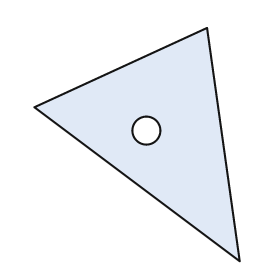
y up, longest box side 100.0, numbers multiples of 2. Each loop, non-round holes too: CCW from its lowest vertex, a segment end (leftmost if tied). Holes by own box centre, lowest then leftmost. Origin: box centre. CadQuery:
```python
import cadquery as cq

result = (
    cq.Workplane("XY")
    .moveTo(44.0, -50.0)
    .lineTo(30.0, 50.0)
    .lineTo(-44.0, 16.0)
    .close()
    .moveTo(4.0, 6.0)
    .circle(6.0)
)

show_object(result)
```